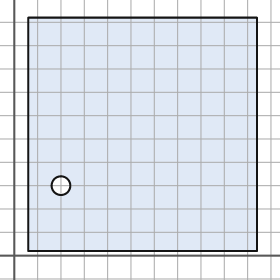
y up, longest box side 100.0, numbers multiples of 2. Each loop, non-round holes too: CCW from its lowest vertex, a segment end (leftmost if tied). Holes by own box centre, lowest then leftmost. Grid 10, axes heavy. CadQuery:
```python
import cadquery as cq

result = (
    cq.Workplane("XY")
    .moveTo(6.0, 2.0)
    .lineTo(104.0, 2.0)
    .lineTo(104.0, 102.0)
    .lineTo(6.0, 102.0)
    .close()
    .moveTo(20.0, 30.0)
    .circle(4.0)
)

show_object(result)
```